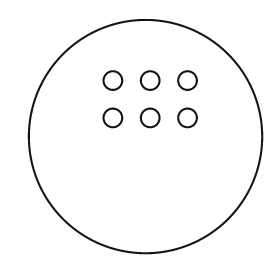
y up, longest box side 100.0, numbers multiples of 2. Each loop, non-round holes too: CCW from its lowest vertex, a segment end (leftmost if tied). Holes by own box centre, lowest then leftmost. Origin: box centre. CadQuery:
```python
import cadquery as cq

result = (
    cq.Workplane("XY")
    .moveTo(0.0, 0.0)
    .circle(50.0)
    .moveTo(-14.0, 8.0)
    .circle(4.0)
    .moveTo(2.0, 8.0)
    .circle(4.0)
    .moveTo(18.0, 8.0)
    .circle(4.0)
    .moveTo(-14.0, 24.0)
    .circle(4.0)
    .moveTo(2.0, 24.0)
    .circle(4.0)
    .moveTo(18.0, 24.0)
    .circle(4.0)
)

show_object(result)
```